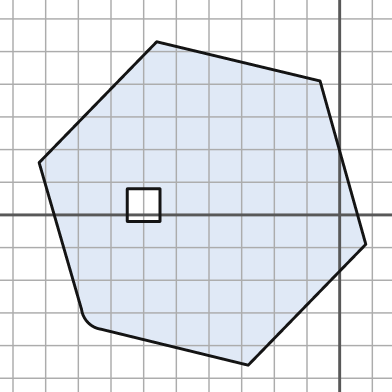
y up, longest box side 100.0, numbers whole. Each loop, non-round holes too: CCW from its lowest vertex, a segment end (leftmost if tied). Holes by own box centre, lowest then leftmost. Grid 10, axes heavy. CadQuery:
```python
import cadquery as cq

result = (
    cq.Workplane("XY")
    .moveTo(-28.0, -46.0)
    .lineTo(8.0, -9.0)
    .lineTo(-6.0, 41.0)
    .lineTo(-56.0, 53.0)
    .lineTo(-92.0, 16.0)
    .lineTo(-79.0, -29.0)
    .threePointArc((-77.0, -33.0), (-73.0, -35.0))
    .close()
    .moveTo(-65.0, -2.0)
    .lineTo(-55.0, -2.0)
    .lineTo(-55.0, 8.0)
    .lineTo(-65.0, 8.0)
    .close()
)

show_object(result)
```